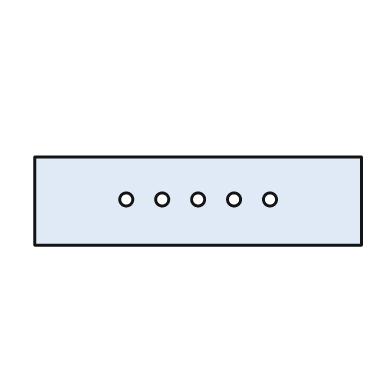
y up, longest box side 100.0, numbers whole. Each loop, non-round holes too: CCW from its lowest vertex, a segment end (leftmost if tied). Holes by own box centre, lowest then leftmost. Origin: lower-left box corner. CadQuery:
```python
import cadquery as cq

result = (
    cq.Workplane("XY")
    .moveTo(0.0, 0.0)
    .lineTo(100.0, 0.0)
    .lineTo(100.0, 27.0)
    .lineTo(0.0, 27.0)
    .close()
    .moveTo(28.0, 14.0)
    .circle(2.0)
    .moveTo(39.0, 14.0)
    .circle(2.0)
    .moveTo(50.0, 14.0)
    .circle(2.0)
    .moveTo(61.0, 14.0)
    .circle(2.0)
    .moveTo(72.0, 14.0)
    .circle(2.0)
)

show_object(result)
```